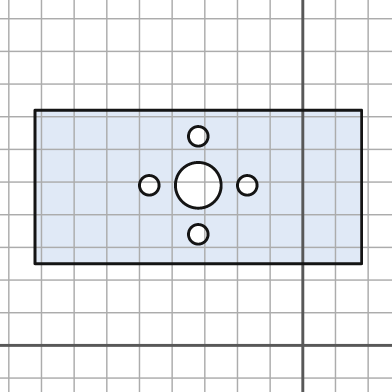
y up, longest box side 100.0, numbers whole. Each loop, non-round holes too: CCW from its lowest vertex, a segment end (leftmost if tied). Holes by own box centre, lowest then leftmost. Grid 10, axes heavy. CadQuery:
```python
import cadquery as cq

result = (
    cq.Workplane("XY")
    .moveTo(-82.0, 25.0)
    .lineTo(18.0, 25.0)
    .lineTo(18.0, 72.0)
    .lineTo(-82.0, 72.0)
    .close()
    .moveTo(-32.0, 34.0)
    .circle(3.0)
    .moveTo(-47.0, 49.0)
    .circle(3.0)
    .moveTo(-32.0, 49.0)
    .circle(7.0)
    .moveTo(-17.0, 49.0)
    .circle(3.0)
    .moveTo(-32.0, 64.0)
    .circle(3.0)
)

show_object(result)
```